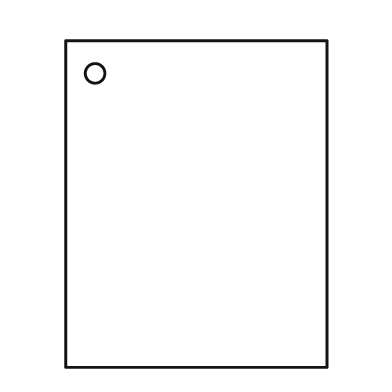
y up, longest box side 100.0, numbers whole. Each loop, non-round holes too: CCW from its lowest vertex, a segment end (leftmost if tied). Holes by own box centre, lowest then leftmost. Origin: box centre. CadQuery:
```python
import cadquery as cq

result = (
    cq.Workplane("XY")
    .moveTo(-40.0, -50.0)
    .lineTo(40.0, -50.0)
    .lineTo(40.0, 50.0)
    .lineTo(-40.0, 50.0)
    .close()
    .moveTo(-31.0, 40.0)
    .circle(3.0)
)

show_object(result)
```